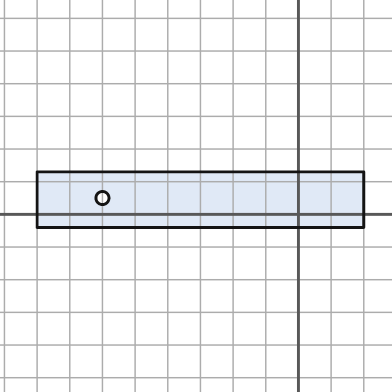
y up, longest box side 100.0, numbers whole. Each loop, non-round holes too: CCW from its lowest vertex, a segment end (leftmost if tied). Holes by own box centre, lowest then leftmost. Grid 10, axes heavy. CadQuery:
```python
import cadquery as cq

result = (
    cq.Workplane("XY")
    .moveTo(-80.0, -4.0)
    .lineTo(20.0, -4.0)
    .lineTo(20.0, 13.0)
    .lineTo(-80.0, 13.0)
    .close()
    .moveTo(-60.0, 5.0)
    .circle(2.0)
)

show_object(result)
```